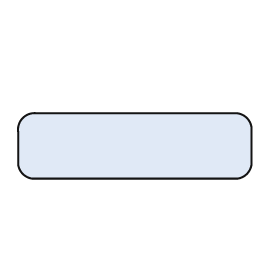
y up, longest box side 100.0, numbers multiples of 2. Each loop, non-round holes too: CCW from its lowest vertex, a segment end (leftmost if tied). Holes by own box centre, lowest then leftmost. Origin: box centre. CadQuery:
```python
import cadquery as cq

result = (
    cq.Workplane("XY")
    .moveTo(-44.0, -14.0)
    .lineTo(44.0, -14.0)
    .threePointArc((48.0, -12.0), (50.0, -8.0))
    .lineTo(50.0, 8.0)
    .threePointArc((48.0, 12.0), (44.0, 14.0))
    .lineTo(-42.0, 14.0)
    .threePointArc((-48.0, 12.0), (-50.0, 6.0))
    .lineTo(-50.0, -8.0)
    .threePointArc((-48.0, -12.0), (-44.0, -14.0))
    .close()
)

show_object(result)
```